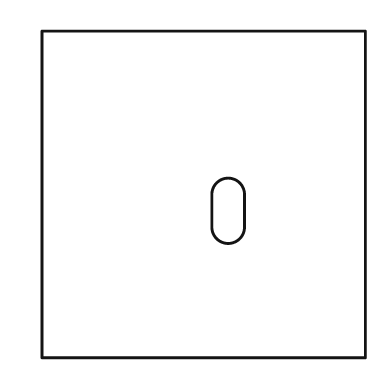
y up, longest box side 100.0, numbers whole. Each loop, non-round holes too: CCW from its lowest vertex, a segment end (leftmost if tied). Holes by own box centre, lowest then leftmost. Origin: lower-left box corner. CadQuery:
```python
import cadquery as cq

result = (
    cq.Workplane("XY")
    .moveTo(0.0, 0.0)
    .lineTo(99.0, 0.0)
    .lineTo(99.0, 100.0)
    .lineTo(0.0, 100.0)
    .close()
    .moveTo(52.0, 40.0)
    .threePointArc((57.0, 35.0), (62.0, 40.0))
    .lineTo(62.0, 50.0)
    .threePointArc((57.0, 55.0), (52.0, 50.0))
    .close()
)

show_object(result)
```